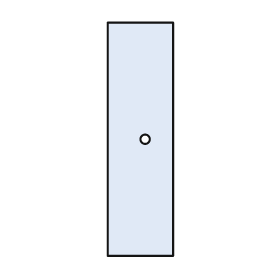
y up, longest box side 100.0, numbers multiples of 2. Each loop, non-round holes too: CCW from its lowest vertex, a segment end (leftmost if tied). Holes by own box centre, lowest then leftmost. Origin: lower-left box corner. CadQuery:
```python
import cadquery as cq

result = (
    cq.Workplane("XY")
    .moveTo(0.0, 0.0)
    .lineTo(28.0, 0.0)
    .lineTo(28.0, 100.0)
    .lineTo(0.0, 100.0)
    .close()
    .moveTo(16.0, 50.0)
    .circle(2.0)
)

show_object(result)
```